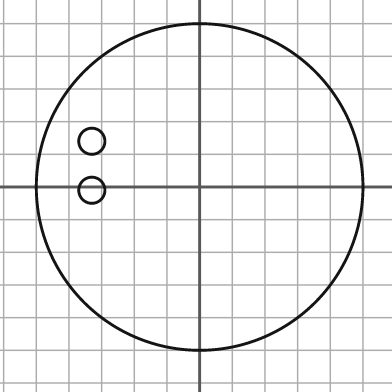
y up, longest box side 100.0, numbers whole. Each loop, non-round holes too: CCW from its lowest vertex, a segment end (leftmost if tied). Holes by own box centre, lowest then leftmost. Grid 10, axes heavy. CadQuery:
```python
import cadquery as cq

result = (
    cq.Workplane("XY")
    .moveTo(0.0, 0.0)
    .circle(50.0)
    .moveTo(-33.0, -1.0)
    .circle(4.0)
    .moveTo(-33.0, 14.0)
    .circle(4.0)
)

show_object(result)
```